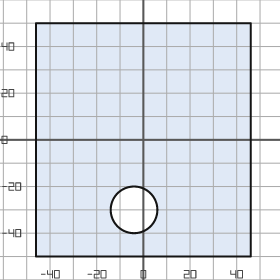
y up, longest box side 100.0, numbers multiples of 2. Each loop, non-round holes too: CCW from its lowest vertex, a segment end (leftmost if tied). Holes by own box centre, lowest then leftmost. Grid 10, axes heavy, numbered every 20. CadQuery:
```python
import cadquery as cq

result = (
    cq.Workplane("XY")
    .moveTo(-46.0, -50.0)
    .lineTo(46.0, -50.0)
    .lineTo(46.0, 50.0)
    .lineTo(-46.0, 50.0)
    .close()
    .moveTo(-4.0, -30.0)
    .circle(10.0)
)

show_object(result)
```